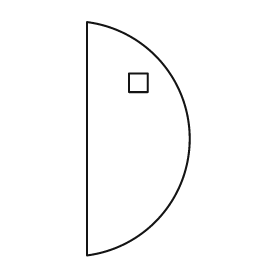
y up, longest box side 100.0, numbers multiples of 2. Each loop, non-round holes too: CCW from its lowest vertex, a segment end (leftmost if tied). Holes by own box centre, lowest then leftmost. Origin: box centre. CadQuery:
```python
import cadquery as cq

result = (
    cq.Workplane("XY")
    .moveTo(-22.0, -50.0)
    .threePointArc((22.0, 0.0), (-22.0, 50.0))
    .close()
    .moveTo(-4.0, 20.0)
    .lineTo(4.0, 20.0)
    .lineTo(4.0, 28.0)
    .lineTo(-4.0, 28.0)
    .close()
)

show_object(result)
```